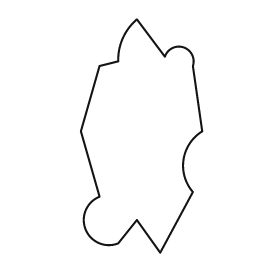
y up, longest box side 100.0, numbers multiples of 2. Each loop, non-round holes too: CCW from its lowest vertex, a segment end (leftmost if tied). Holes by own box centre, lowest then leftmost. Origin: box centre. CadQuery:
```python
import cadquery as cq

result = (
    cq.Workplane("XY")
    .moveTo(8.0, -50.0)
    .lineTo(22.0, -24.0)
    .threePointArc((18.0, -10.0), (26.0, 2.0))
    .lineTo(22.0, 30.0)
    .threePointArc((18.0, 38.0), (10.0, 34.0))
    .lineTo(-2.0, 50.0)
    .threePointArc((-8.0, 42.0), (-10.0, 32.0))
    .lineTo(-18.0, 30.0)
    .lineTo(-26.0, 2.0)
    .lineTo(-18.0, -26.0)
    .threePointArc((-24.0, -40.0), (-10.0, -46.0))
    .lineTo(-2.0, -36.0)
    .close()
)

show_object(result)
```